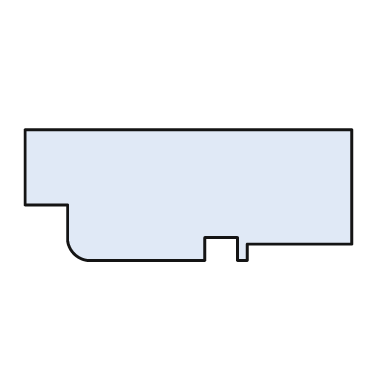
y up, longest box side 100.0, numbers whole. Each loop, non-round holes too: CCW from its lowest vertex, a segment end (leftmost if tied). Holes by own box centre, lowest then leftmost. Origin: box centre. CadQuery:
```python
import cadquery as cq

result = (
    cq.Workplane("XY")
    .moveTo(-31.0, -20.0)
    .lineTo(5.0, -20.0)
    .lineTo(5.0, -13.0)
    .lineTo(15.0, -13.0)
    .lineTo(15.0, -20.0)
    .lineTo(18.0, -20.0)
    .lineTo(18.0, -15.0)
    .lineTo(50.0, -15.0)
    .lineTo(50.0, 20.0)
    .lineTo(-50.0, 20.0)
    .lineTo(-50.0, -3.0)
    .lineTo(-37.0, -3.0)
    .lineTo(-37.0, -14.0)
    .threePointArc((-35.0, -18.0), (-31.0, -20.0))
    .close()
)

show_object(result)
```